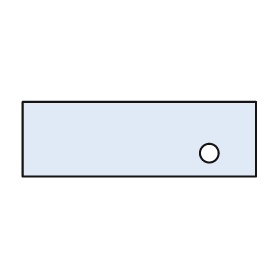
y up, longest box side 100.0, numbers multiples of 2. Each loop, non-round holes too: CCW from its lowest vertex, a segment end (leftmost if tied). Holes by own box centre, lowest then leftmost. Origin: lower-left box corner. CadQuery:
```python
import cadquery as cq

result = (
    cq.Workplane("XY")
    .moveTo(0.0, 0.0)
    .lineTo(100.0, 0.0)
    .lineTo(100.0, 32.0)
    .lineTo(0.0, 32.0)
    .close()
    .moveTo(80.0, 10.0)
    .circle(4.0)
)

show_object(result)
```